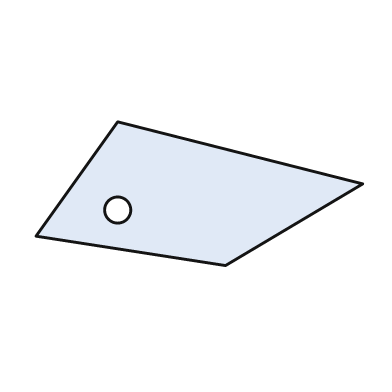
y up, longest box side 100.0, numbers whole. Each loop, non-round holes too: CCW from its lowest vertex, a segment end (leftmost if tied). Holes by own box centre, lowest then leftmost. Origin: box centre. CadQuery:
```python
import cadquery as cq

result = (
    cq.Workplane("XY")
    .moveTo(8.0, -22.0)
    .lineTo(50.0, 3.0)
    .lineTo(-25.0, 22.0)
    .lineTo(-50.0, -13.0)
    .close()
    .moveTo(-25.0, -5.0)
    .circle(4.0)
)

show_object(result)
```